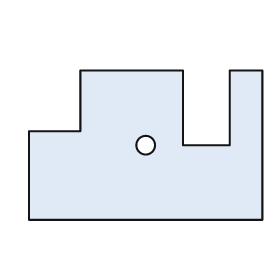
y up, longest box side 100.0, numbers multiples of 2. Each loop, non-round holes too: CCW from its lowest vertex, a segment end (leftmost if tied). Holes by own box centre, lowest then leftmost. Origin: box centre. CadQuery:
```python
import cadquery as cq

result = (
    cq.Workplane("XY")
    .moveTo(-50.0, -32.0)
    .lineTo(50.0, -32.0)
    .lineTo(50.0, 32.0)
    .lineTo(36.0, 32.0)
    .lineTo(36.0, 0.0)
    .lineTo(16.0, 0.0)
    .lineTo(16.0, 32.0)
    .lineTo(-28.0, 32.0)
    .lineTo(-28.0, 6.0)
    .lineTo(-50.0, 6.0)
    .close()
    .moveTo(0.0, 0.0)
    .circle(4.0)
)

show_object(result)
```